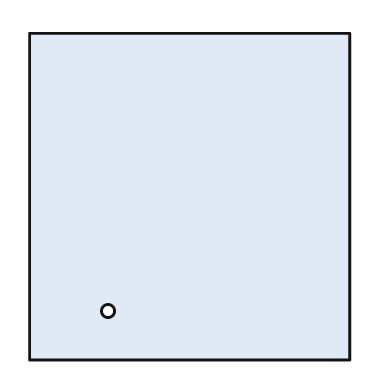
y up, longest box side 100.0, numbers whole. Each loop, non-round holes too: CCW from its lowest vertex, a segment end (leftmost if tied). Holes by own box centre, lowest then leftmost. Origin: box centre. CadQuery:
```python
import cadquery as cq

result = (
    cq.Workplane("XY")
    .moveTo(-49.0, -50.0)
    .lineTo(49.0, -50.0)
    .lineTo(49.0, 50.0)
    .lineTo(-49.0, 50.0)
    .close()
    .moveTo(-25.0, -35.0)
    .circle(2.0)
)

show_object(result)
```